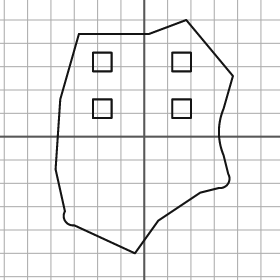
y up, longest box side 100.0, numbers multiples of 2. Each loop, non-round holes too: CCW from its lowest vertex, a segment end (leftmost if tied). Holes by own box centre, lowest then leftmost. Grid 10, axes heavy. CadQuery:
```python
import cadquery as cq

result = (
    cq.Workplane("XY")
    .moveTo(-4.0, -50.0)
    .lineTo(6.0, -36.0)
    .lineTo(24.0, -24.0)
    .lineTo(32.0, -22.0)
    .threePointArc((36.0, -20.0), (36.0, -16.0))
    .lineTo(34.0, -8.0)
    .threePointArc((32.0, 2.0), (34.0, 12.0))
    .lineTo(38.0, 26.0)
    .lineTo(18.0, 50.0)
    .lineTo(2.0, 44.0)
    .lineTo(-28.0, 44.0)
    .lineTo(-36.0, 16.0)
    .lineTo(-38.0, -14.0)
    .lineTo(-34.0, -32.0)
    .threePointArc((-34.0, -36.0), (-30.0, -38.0))
    .close()
    .moveTo(-22.0, 8.0)
    .lineTo(-14.0, 8.0)
    .lineTo(-14.0, 16.0)
    .lineTo(-22.0, 16.0)
    .close()
    .moveTo(12.0, 8.0)
    .lineTo(20.0, 8.0)
    .lineTo(20.0, 16.0)
    .lineTo(12.0, 16.0)
    .close()
    .moveTo(-22.0, 28.0)
    .lineTo(-14.0, 28.0)
    .lineTo(-14.0, 36.0)
    .lineTo(-22.0, 36.0)
    .close()
    .moveTo(12.0, 28.0)
    .lineTo(20.0, 28.0)
    .lineTo(20.0, 36.0)
    .lineTo(12.0, 36.0)
    .close()
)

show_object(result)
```